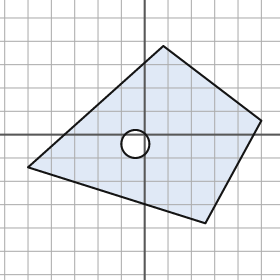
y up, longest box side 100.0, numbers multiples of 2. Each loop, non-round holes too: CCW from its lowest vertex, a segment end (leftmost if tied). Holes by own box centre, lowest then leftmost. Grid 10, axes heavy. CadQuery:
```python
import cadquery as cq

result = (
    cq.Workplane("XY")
    .moveTo(26.0, -38.0)
    .lineTo(50.0, 6.0)
    .lineTo(8.0, 38.0)
    .lineTo(-50.0, -14.0)
    .close()
    .moveTo(-4.0, -4.0)
    .circle(6.0)
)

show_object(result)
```